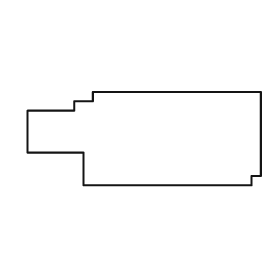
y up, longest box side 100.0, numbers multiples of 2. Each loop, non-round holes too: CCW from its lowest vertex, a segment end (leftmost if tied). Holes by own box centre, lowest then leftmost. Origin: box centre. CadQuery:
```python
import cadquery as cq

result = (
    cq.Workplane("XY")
    .moveTo(-26.0, -20.0)
    .lineTo(46.0, -20.0)
    .lineTo(46.0, -16.0)
    .lineTo(50.0, -16.0)
    .lineTo(50.0, 20.0)
    .lineTo(-22.0, 20.0)
    .lineTo(-22.0, 16.0)
    .lineTo(-30.0, 16.0)
    .lineTo(-30.0, 12.0)
    .lineTo(-50.0, 12.0)
    .lineTo(-50.0, -6.0)
    .lineTo(-26.0, -6.0)
    .close()
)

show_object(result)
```